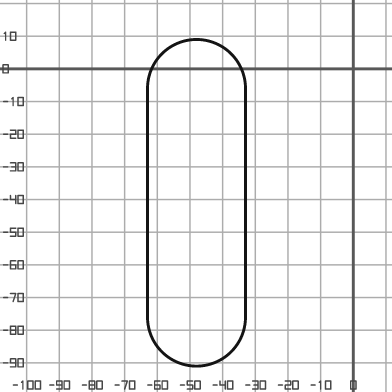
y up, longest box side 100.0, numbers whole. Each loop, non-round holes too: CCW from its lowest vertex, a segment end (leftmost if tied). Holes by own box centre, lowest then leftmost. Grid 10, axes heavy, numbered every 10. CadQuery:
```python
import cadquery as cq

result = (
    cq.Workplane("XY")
    .moveTo(-63.0, -76.0)
    .threePointArc((-48.0, -91.0), (-33.0, -76.0))
    .lineTo(-33.0, -6.0)
    .threePointArc((-48.0, 9.0), (-63.0, -6.0))
    .close()
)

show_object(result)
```